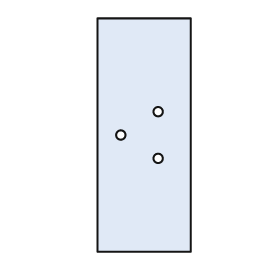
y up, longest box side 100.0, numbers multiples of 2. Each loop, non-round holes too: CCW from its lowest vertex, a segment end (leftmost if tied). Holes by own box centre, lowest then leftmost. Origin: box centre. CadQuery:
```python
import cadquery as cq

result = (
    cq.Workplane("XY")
    .moveTo(-20.0, -50.0)
    .lineTo(20.0, -50.0)
    .lineTo(20.0, 50.0)
    .lineTo(-20.0, 50.0)
    .close()
    .moveTo(6.0, -10.0)
    .circle(2.0)
    .moveTo(-10.0, 0.0)
    .circle(2.0)
    .moveTo(6.0, 10.0)
    .circle(2.0)
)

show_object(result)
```